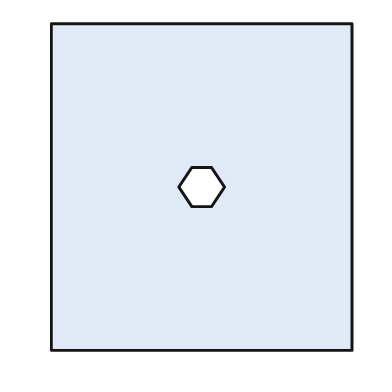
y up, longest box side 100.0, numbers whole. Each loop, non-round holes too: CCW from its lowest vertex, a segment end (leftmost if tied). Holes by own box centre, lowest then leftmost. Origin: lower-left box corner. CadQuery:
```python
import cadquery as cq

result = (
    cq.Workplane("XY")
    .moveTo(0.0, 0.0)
    .lineTo(92.0, 0.0)
    .lineTo(92.0, 100.0)
    .lineTo(0.0, 100.0)
    .close()
    .moveTo(43.0, 44.0)
    .lineTo(49.0, 44.0)
    .lineTo(53.0, 50.0)
    .lineTo(49.0, 56.0)
    .lineTo(43.0, 56.0)
    .lineTo(39.0, 50.0)
    .close()
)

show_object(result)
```